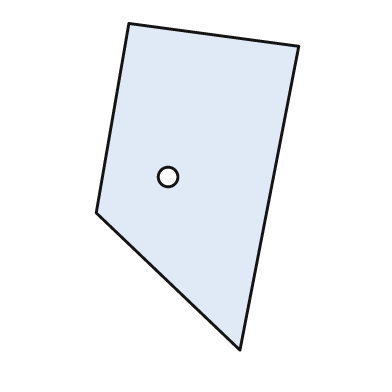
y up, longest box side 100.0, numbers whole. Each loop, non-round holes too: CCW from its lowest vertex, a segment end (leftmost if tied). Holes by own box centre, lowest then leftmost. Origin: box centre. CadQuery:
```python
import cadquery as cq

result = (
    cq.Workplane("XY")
    .moveTo(13.0, -50.0)
    .lineTo(31.0, 43.0)
    .lineTo(-21.0, 50.0)
    .lineTo(-31.0, -8.0)
    .close()
    .moveTo(-9.0, 3.0)
    .circle(3.0)
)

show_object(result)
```